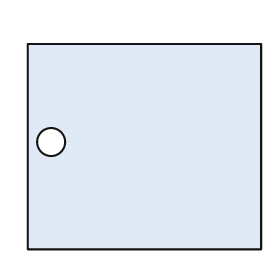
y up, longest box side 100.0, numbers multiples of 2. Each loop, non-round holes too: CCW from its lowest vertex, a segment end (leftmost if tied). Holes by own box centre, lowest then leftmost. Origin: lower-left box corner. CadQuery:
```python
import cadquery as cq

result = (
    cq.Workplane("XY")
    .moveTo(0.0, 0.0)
    .lineTo(100.0, 0.0)
    .lineTo(100.0, 88.0)
    .lineTo(0.0, 88.0)
    .close()
    .moveTo(10.0, 46.0)
    .circle(6.0)
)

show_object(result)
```